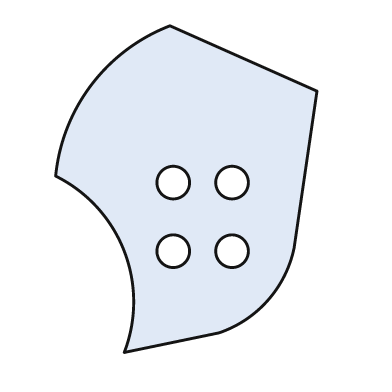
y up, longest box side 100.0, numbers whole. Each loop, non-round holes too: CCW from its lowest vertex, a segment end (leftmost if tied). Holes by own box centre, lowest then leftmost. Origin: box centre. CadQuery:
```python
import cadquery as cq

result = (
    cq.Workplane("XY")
    .moveTo(-19.0, -50.0)
    .lineTo(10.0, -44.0)
    .threePointArc((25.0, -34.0), (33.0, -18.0))
    .lineTo(40.0, 30.0)
    .lineTo(-5.0, 50.0)
    .threePointArc((-29.0, 32.0), (-40.0, 4.0))
    .threePointArc((-19.0, -19.0), (-19.0, -50.0))
    .close()
    .moveTo(-4.0, -19.0)
    .circle(5.0)
    .moveTo(14.0, -19.0)
    .circle(5.0)
    .moveTo(-4.0, 2.0)
    .circle(5.0)
    .moveTo(14.0, 2.0)
    .circle(5.0)
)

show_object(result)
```